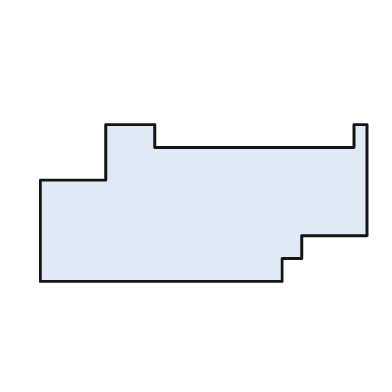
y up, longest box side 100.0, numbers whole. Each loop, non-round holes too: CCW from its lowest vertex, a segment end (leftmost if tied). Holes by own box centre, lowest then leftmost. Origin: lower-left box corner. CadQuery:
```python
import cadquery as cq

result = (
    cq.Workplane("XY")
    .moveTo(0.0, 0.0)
    .lineTo(74.0, 0.0)
    .lineTo(74.0, 7.0)
    .lineTo(80.0, 7.0)
    .lineTo(80.0, 14.0)
    .lineTo(100.0, 14.0)
    .lineTo(100.0, 48.0)
    .lineTo(96.0, 48.0)
    .lineTo(96.0, 41.0)
    .lineTo(35.0, 41.0)
    .lineTo(35.0, 48.0)
    .lineTo(20.0, 48.0)
    .lineTo(20.0, 31.0)
    .lineTo(0.0, 31.0)
    .close()
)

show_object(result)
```